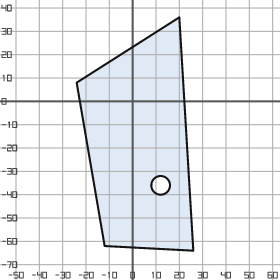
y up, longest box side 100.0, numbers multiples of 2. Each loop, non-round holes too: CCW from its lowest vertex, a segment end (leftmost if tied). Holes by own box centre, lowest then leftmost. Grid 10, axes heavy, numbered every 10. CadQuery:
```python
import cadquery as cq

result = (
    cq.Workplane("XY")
    .moveTo(26.0, -64.0)
    .lineTo(20.0, 36.0)
    .lineTo(-24.0, 8.0)
    .lineTo(-12.0, -62.0)
    .close()
    .moveTo(12.0, -36.0)
    .circle(4.0)
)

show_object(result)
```